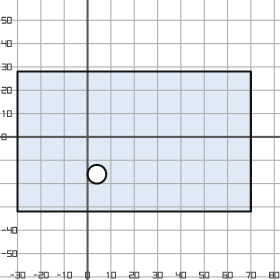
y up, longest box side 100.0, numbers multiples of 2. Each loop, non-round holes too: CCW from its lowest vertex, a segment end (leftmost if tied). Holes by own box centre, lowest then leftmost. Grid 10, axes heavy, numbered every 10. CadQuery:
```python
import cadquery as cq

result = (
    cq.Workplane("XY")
    .moveTo(-30.0, -32.0)
    .lineTo(70.0, -32.0)
    .lineTo(70.0, 28.0)
    .lineTo(-30.0, 28.0)
    .close()
    .moveTo(4.0, -16.0)
    .circle(4.0)
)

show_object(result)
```